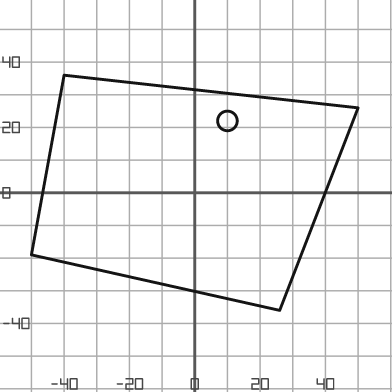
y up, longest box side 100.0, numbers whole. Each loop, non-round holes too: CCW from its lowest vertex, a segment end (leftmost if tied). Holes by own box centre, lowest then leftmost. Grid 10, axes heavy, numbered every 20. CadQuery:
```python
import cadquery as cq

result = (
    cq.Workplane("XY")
    .moveTo(26.0, -36.0)
    .lineTo(50.0, 26.0)
    .lineTo(-40.0, 36.0)
    .lineTo(-50.0, -19.0)
    .close()
    .moveTo(10.0, 22.0)
    .circle(3.0)
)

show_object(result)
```